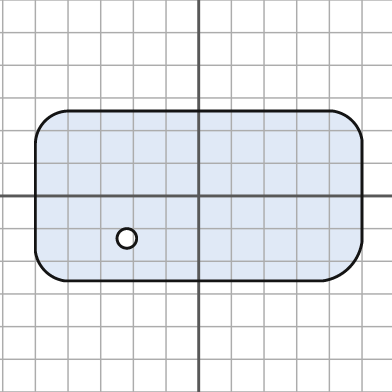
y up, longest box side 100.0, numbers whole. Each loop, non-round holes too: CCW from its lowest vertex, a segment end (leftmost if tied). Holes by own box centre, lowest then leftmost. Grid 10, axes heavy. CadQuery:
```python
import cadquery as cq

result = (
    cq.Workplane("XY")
    .moveTo(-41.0, -26.0)
    .lineTo(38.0, -26.0)
    .threePointArc((46.0, -22.0), (50.0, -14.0))
    .lineTo(50.0, 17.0)
    .threePointArc((47.0, 23.0), (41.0, 26.0))
    .lineTo(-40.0, 26.0)
    .threePointArc((-47.0, 23.0), (-50.0, 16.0))
    .lineTo(-50.0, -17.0)
    .threePointArc((-47.0, -23.0), (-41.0, -26.0))
    .close()
    .moveTo(-22.0, -13.0)
    .circle(3.0)
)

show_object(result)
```